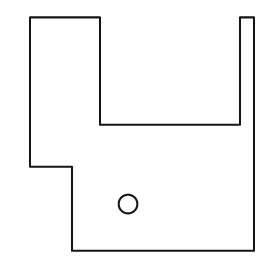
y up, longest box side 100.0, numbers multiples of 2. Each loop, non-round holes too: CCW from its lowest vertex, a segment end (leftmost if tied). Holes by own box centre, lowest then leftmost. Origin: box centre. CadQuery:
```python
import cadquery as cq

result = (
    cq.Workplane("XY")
    .moveTo(-30.0, -50.0)
    .lineTo(48.0, -50.0)
    .lineTo(48.0, 50.0)
    .lineTo(42.0, 50.0)
    .lineTo(42.0, 4.0)
    .lineTo(-18.0, 4.0)
    .lineTo(-18.0, 50.0)
    .lineTo(-48.0, 50.0)
    .lineTo(-48.0, -14.0)
    .lineTo(-30.0, -14.0)
    .close()
    .moveTo(-6.0, -30.0)
    .circle(4.0)
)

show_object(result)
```